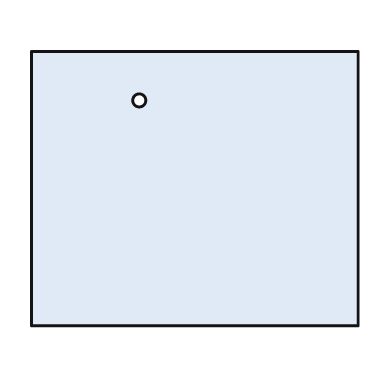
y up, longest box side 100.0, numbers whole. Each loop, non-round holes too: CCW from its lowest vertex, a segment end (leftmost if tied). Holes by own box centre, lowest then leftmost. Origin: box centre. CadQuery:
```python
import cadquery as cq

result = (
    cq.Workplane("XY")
    .moveTo(-50.0, -42.0)
    .lineTo(50.0, -42.0)
    .lineTo(50.0, 42.0)
    .lineTo(-50.0, 42.0)
    .close()
    .moveTo(-17.0, 27.0)
    .circle(2.0)
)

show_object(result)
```